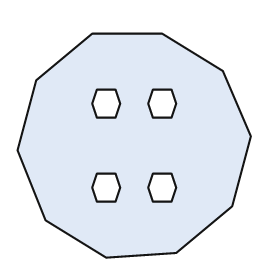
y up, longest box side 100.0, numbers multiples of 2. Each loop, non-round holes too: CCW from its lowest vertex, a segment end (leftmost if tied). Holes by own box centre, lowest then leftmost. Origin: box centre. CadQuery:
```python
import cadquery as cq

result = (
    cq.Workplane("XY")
    .moveTo(-12.0, -48.0)
    .lineTo(18.0, -46.0)
    .lineTo(42.0, -26.0)
    .lineTo(50.0, 4.0)
    .lineTo(38.0, 32.0)
    .lineTo(12.0, 48.0)
    .lineTo(-18.0, 48.0)
    .lineTo(-42.0, 28.0)
    .lineTo(-50.0, -2.0)
    .lineTo(-38.0, -32.0)
    .close()
    .moveTo(-16.0, -24.0)
    .lineTo(-8.0, -24.0)
    .lineTo(-6.0, -18.0)
    .lineTo(-8.0, -12.0)
    .lineTo(-16.0, -12.0)
    .lineTo(-18.0, -18.0)
    .close()
    .moveTo(8.0, -24.0)
    .lineTo(16.0, -24.0)
    .lineTo(18.0, -18.0)
    .lineTo(16.0, -12.0)
    .lineTo(8.0, -12.0)
    .lineTo(6.0, -18.0)
    .close()
    .moveTo(-16.0, 12.0)
    .lineTo(-8.0, 12.0)
    .lineTo(-6.0, 18.0)
    .lineTo(-8.0, 24.0)
    .lineTo(-16.0, 24.0)
    .lineTo(-18.0, 18.0)
    .close()
    .moveTo(8.0, 12.0)
    .lineTo(16.0, 12.0)
    .lineTo(18.0, 18.0)
    .lineTo(16.0, 24.0)
    .lineTo(8.0, 24.0)
    .lineTo(6.0, 18.0)
    .close()
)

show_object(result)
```